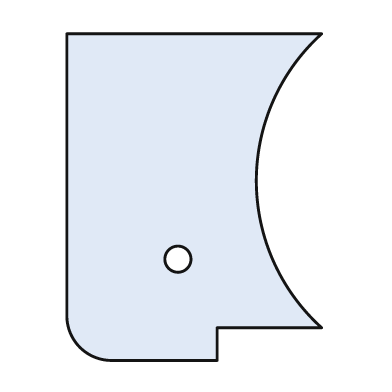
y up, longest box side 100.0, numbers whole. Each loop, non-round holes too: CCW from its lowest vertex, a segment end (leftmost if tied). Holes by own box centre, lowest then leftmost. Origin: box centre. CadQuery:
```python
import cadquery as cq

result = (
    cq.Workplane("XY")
    .moveTo(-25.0, -50.0)
    .lineTo(7.0, -50.0)
    .lineTo(7.0, -40.0)
    .lineTo(39.0, -40.0)
    .threePointArc((19.0, 5.0), (39.0, 50.0))
    .lineTo(-39.0, 50.0)
    .lineTo(-39.0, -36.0)
    .threePointArc((-35.0, -46.0), (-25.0, -50.0))
    .close()
    .moveTo(-5.0, -19.0)
    .circle(4.0)
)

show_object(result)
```